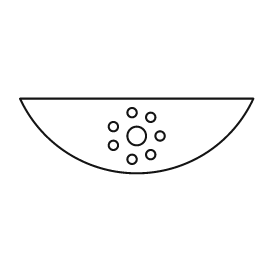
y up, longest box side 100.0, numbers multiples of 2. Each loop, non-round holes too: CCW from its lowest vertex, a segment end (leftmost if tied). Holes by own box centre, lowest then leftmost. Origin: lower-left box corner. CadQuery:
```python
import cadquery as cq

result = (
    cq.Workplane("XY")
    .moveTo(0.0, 32.0)
    .threePointArc((50.0, 0.0), (100.0, 32.0))
    .close()
    .moveTo(48.0, 6.0)
    .circle(2.0)
    .moveTo(56.0, 8.0)
    .circle(2.0)
    .moveTo(40.0, 12.0)
    .circle(2.0)
    .moveTo(50.0, 16.0)
    .circle(4.0)
    .moveTo(60.0, 16.0)
    .circle(2.0)
    .moveTo(40.0, 20.0)
    .circle(2.0)
    .moveTo(56.0, 24.0)
    .circle(2.0)
    .moveTo(48.0, 26.0)
    .circle(2.0)
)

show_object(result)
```